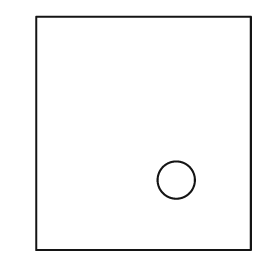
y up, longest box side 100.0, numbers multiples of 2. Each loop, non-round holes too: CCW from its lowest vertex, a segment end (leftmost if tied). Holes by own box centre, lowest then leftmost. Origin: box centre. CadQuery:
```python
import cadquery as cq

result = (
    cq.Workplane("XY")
    .moveTo(-46.0, -50.0)
    .lineTo(46.0, -50.0)
    .lineTo(46.0, 50.0)
    .lineTo(-46.0, 50.0)
    .close()
    .moveTo(14.0, -20.0)
    .circle(8.0)
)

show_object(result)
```